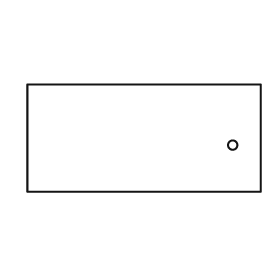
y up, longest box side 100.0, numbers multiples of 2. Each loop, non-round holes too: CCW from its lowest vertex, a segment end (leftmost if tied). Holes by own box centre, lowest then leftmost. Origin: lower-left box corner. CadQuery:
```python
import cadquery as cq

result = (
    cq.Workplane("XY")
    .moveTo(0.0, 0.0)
    .lineTo(100.0, 0.0)
    .lineTo(100.0, 46.0)
    .lineTo(0.0, 46.0)
    .close()
    .moveTo(88.0, 20.0)
    .circle(2.0)
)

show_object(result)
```